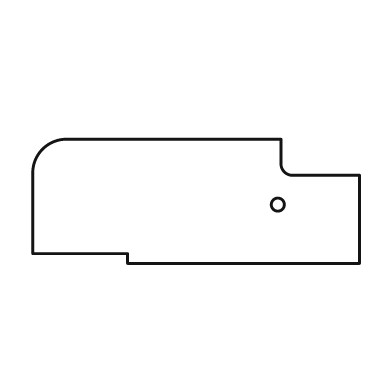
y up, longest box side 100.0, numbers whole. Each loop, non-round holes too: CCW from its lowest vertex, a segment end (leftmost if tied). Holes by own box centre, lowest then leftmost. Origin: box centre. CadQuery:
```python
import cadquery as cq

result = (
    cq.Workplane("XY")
    .moveTo(-21.0, -19.0)
    .lineTo(50.0, -19.0)
    .lineTo(50.0, 8.0)
    .lineTo(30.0, 8.0)
    .threePointArc((27.0, 9.0), (26.0, 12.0))
    .lineTo(26.0, 19.0)
    .lineTo(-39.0, 19.0)
    .threePointArc((-47.0, 16.0), (-50.0, 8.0))
    .lineTo(-50.0, -16.0)
    .lineTo(-21.0, -16.0)
    .close()
    .moveTo(25.0, -1.0)
    .circle(2.0)
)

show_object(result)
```